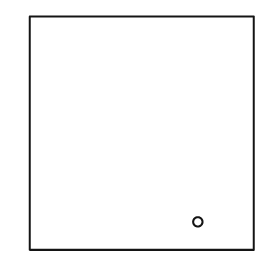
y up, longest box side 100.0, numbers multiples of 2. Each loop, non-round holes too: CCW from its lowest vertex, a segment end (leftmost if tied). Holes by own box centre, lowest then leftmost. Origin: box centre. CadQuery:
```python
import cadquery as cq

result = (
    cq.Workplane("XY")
    .moveTo(-48.0, -50.0)
    .lineTo(48.0, -50.0)
    .lineTo(48.0, 50.0)
    .lineTo(-48.0, 50.0)
    .close()
    .moveTo(24.0, -38.0)
    .circle(2.0)
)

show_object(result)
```